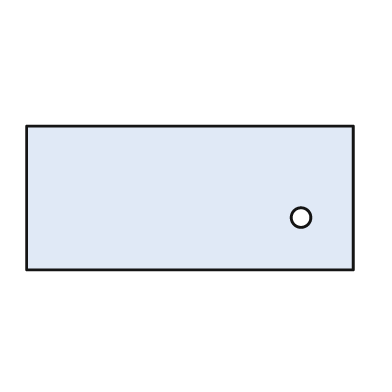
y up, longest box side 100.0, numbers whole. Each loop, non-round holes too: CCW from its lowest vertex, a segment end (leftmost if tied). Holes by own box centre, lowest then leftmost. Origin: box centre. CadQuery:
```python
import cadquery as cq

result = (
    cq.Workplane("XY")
    .moveTo(-50.0, -22.0)
    .lineTo(50.0, -22.0)
    .lineTo(50.0, 22.0)
    .lineTo(-50.0, 22.0)
    .close()
    .moveTo(34.0, -6.0)
    .circle(3.0)
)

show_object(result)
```